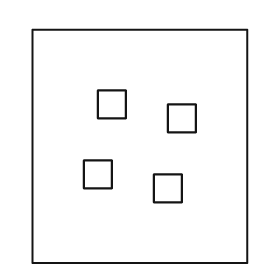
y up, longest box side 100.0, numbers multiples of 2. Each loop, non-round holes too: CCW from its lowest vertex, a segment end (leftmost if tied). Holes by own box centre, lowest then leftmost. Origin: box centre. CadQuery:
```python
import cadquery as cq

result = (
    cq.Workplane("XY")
    .moveTo(-46.0, -50.0)
    .lineTo(46.0, -50.0)
    .lineTo(46.0, 50.0)
    .lineTo(-46.0, 50.0)
    .close()
    .moveTo(6.0, -24.0)
    .lineTo(18.0, -24.0)
    .lineTo(18.0, -12.0)
    .lineTo(6.0, -12.0)
    .close()
    .moveTo(-24.0, -18.0)
    .lineTo(-12.0, -18.0)
    .lineTo(-12.0, -6.0)
    .lineTo(-24.0, -6.0)
    .close()
    .moveTo(12.0, 6.0)
    .lineTo(24.0, 6.0)
    .lineTo(24.0, 18.0)
    .lineTo(12.0, 18.0)
    .close()
    .moveTo(-18.0, 12.0)
    .lineTo(-6.0, 12.0)
    .lineTo(-6.0, 24.0)
    .lineTo(-18.0, 24.0)
    .close()
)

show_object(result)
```